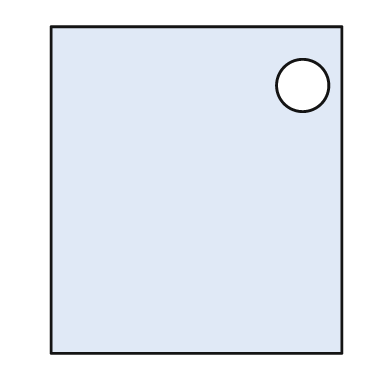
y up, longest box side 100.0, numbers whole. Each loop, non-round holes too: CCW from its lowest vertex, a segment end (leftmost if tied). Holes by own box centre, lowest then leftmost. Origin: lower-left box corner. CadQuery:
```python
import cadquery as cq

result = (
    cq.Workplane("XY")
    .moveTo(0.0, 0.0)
    .lineTo(89.0, 0.0)
    .lineTo(89.0, 100.0)
    .lineTo(0.0, 100.0)
    .close()
    .moveTo(77.0, 82.0)
    .circle(8.0)
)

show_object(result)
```